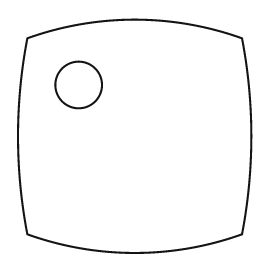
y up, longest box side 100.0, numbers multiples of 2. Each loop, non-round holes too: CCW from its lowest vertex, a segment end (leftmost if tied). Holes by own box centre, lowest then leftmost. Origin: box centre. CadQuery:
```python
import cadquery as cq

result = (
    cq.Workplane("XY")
    .moveTo(-46.0, -42.0)
    .threePointArc((0.0, -50.0), (46.0, -42.0))
    .threePointArc((50.0, 0.0), (46.0, 42.0))
    .threePointArc((0.0, 50.0), (-46.0, 42.0))
    .threePointArc((-50.0, 0.0), (-46.0, -42.0))
    .close()
    .moveTo(-24.0, 22.0)
    .circle(10.0)
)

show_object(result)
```